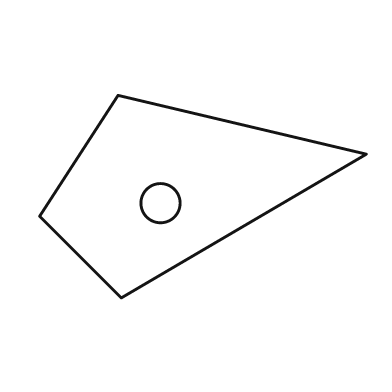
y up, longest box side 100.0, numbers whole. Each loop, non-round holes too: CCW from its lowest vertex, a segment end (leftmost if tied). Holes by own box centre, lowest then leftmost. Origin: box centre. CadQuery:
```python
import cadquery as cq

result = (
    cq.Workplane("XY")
    .moveTo(-25.0, -31.0)
    .lineTo(50.0, 13.0)
    .lineTo(-26.0, 31.0)
    .lineTo(-50.0, -6.0)
    .close()
    .moveTo(-13.0, -2.0)
    .circle(6.0)
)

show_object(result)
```